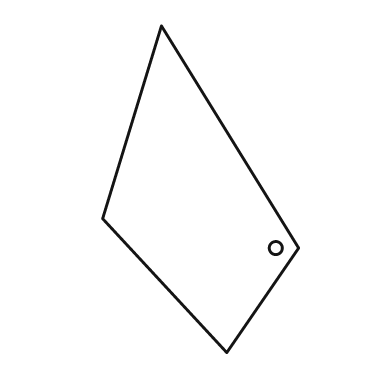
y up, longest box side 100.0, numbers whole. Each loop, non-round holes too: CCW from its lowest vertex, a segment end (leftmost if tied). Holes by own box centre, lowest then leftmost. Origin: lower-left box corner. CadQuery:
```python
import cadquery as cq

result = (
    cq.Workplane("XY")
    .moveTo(38.0, 0.0)
    .lineTo(60.0, 32.0)
    .lineTo(18.0, 100.0)
    .lineTo(0.0, 41.0)
    .close()
    .moveTo(53.0, 32.0)
    .circle(2.0)
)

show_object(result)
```